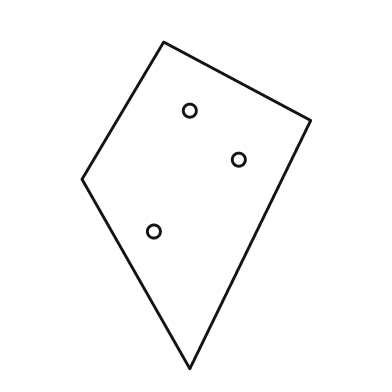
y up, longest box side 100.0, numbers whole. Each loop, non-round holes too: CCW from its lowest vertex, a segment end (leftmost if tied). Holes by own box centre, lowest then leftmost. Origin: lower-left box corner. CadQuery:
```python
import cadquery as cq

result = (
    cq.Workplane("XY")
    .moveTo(33.0, 0.0)
    .lineTo(70.0, 76.0)
    .lineTo(25.0, 100.0)
    .lineTo(0.0, 58.0)
    .close()
    .moveTo(22.0, 42.0)
    .circle(2.0)
    .moveTo(48.0, 64.0)
    .circle(2.0)
    .moveTo(33.0, 79.0)
    .circle(2.0)
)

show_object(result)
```